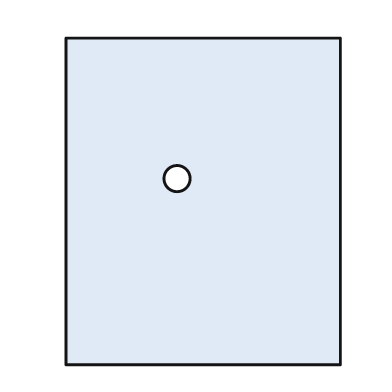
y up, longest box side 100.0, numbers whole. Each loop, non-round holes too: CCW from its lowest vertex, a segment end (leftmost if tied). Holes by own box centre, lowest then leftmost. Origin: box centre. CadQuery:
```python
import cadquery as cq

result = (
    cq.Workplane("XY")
    .moveTo(-42.0, -50.0)
    .lineTo(42.0, -50.0)
    .lineTo(42.0, 50.0)
    .lineTo(-42.0, 50.0)
    .close()
    .moveTo(-8.0, 7.0)
    .circle(4.0)
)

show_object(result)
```